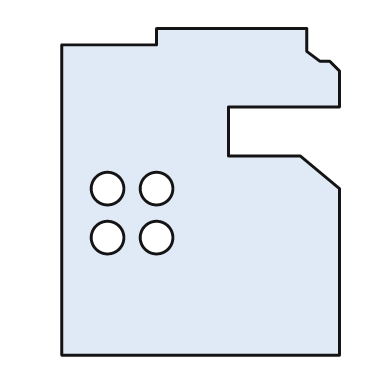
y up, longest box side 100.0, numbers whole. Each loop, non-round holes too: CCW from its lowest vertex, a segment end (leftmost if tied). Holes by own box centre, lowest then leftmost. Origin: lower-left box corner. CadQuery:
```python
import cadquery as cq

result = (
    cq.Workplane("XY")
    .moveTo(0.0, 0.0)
    .lineTo(85.0, 0.0)
    .lineTo(85.0, 51.0)
    .lineTo(73.0, 61.0)
    .lineTo(51.0, 61.0)
    .lineTo(51.0, 76.0)
    .lineTo(85.0, 76.0)
    .lineTo(85.0, 87.0)
    .lineTo(82.0, 90.0)
    .lineTo(79.0, 90.0)
    .lineTo(75.0, 93.0)
    .lineTo(75.0, 100.0)
    .lineTo(29.0, 100.0)
    .lineTo(29.0, 95.0)
    .lineTo(0.0, 95.0)
    .close()
    .moveTo(14.0, 36.0)
    .circle(5.0)
    .moveTo(29.0, 36.0)
    .circle(5.0)
    .moveTo(14.0, 51.0)
    .circle(5.0)
    .moveTo(29.0, 51.0)
    .circle(5.0)
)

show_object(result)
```